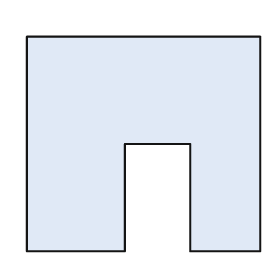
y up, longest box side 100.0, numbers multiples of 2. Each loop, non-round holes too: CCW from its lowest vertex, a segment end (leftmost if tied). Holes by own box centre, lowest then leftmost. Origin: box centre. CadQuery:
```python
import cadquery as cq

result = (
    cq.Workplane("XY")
    .moveTo(-50.0, -46.0)
    .lineTo(-8.0, -46.0)
    .lineTo(-8.0, 0.0)
    .lineTo(20.0, 0.0)
    .lineTo(20.0, -46.0)
    .lineTo(50.0, -46.0)
    .lineTo(50.0, 46.0)
    .lineTo(-50.0, 46.0)
    .close()
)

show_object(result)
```